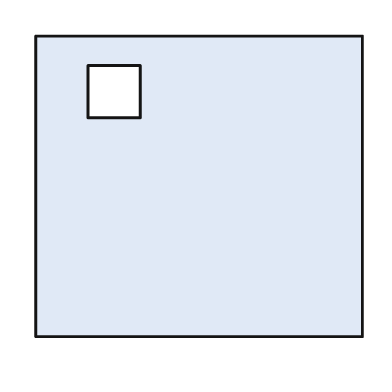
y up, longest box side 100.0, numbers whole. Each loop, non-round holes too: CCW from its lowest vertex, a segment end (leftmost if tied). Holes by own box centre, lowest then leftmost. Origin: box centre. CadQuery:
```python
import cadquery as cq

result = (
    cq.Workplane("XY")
    .moveTo(-50.0, -46.0)
    .lineTo(50.0, -46.0)
    .lineTo(50.0, 46.0)
    .lineTo(-50.0, 46.0)
    .close()
    .moveTo(-34.0, 21.0)
    .lineTo(-18.0, 21.0)
    .lineTo(-18.0, 37.0)
    .lineTo(-34.0, 37.0)
    .close()
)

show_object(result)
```